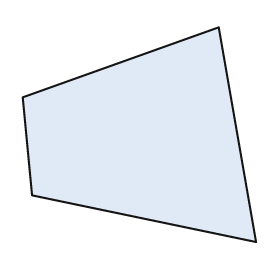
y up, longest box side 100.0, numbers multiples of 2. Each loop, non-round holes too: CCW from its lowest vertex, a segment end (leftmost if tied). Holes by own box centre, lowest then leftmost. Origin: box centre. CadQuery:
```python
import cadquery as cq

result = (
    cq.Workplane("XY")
    .moveTo(50.0, -46.0)
    .lineTo(34.0, 46.0)
    .lineTo(-50.0, 16.0)
    .lineTo(-46.0, -26.0)
    .close()
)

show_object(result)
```